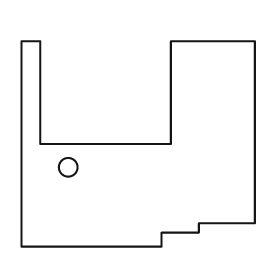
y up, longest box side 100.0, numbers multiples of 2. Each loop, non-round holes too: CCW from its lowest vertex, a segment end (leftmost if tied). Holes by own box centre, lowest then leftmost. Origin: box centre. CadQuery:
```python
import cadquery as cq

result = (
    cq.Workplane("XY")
    .moveTo(-50.0, -44.0)
    .lineTo(10.0, -44.0)
    .lineTo(10.0, -38.0)
    .lineTo(26.0, -38.0)
    .lineTo(26.0, -34.0)
    .lineTo(50.0, -34.0)
    .lineTo(50.0, 44.0)
    .lineTo(14.0, 44.0)
    .lineTo(14.0, 0.0)
    .lineTo(-42.0, 0.0)
    .lineTo(-42.0, 44.0)
    .lineTo(-50.0, 44.0)
    .close()
    .moveTo(-30.0, -10.0)
    .circle(4.0)
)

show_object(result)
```